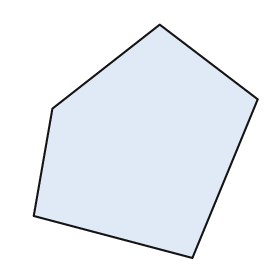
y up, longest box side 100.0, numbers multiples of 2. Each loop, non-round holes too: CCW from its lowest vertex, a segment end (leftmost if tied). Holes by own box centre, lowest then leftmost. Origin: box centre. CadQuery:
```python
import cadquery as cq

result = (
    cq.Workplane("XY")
    .moveTo(20.0, -50.0)
    .lineTo(48.0, 18.0)
    .lineTo(6.0, 50.0)
    .lineTo(-40.0, 14.0)
    .lineTo(-48.0, -32.0)
    .close()
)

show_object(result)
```